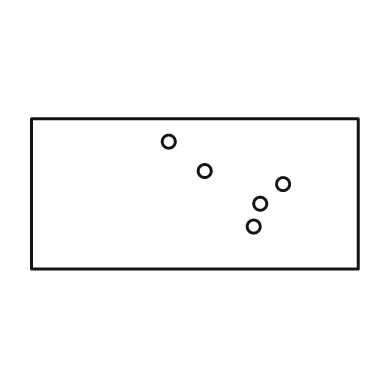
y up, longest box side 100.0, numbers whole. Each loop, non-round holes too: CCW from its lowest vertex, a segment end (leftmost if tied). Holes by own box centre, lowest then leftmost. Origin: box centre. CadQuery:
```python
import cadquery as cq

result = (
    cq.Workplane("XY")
    .moveTo(-50.0, -23.0)
    .lineTo(50.0, -23.0)
    .lineTo(50.0, 23.0)
    .lineTo(-50.0, 23.0)
    .close()
    .moveTo(18.0, -10.0)
    .circle(2.0)
    .moveTo(20.0, -3.0)
    .circle(2.0)
    .moveTo(27.0, 3.0)
    .circle(2.0)
    .moveTo(3.0, 7.0)
    .circle(2.0)
    .moveTo(-8.0, 16.0)
    .circle(2.0)
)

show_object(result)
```